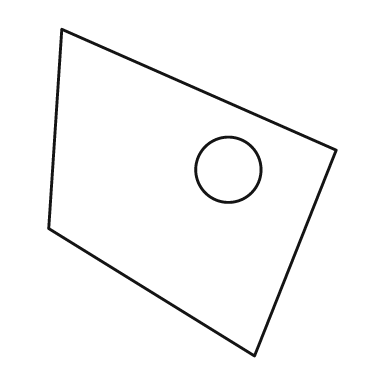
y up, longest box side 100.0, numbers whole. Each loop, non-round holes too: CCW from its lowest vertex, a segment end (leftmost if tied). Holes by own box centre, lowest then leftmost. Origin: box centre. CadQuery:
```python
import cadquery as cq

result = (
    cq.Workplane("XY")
    .moveTo(19.0, -50.0)
    .lineTo(44.0, 13.0)
    .lineTo(-40.0, 50.0)
    .lineTo(-44.0, -11.0)
    .close()
    .moveTo(11.0, 7.0)
    .circle(10.0)
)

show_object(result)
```